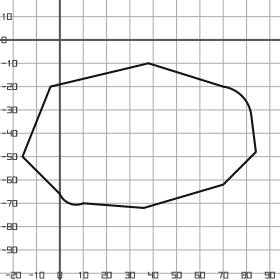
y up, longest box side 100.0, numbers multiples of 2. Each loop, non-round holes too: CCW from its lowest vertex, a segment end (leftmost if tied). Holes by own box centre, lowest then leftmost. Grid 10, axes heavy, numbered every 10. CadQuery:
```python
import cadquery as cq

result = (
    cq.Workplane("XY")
    .moveTo(36.0, -72.0)
    .lineTo(70.0, -62.0)
    .lineTo(84.0, -48.0)
    .lineTo(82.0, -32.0)
    .threePointArc((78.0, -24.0), (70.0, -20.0))
    .lineTo(38.0, -10.0)
    .lineTo(-4.0, -20.0)
    .lineTo(-16.0, -50.0)
    .lineTo(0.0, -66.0)
    .threePointArc((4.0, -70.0), (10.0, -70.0))
    .close()
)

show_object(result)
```